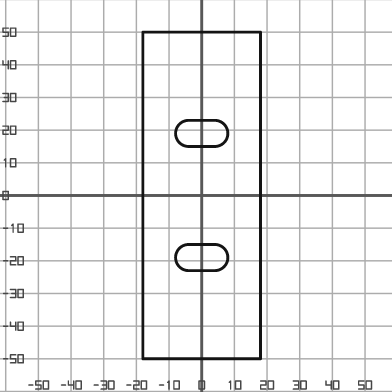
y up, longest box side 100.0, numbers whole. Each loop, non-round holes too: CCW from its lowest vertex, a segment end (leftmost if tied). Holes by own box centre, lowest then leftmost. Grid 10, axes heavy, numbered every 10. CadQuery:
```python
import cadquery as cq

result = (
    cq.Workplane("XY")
    .moveTo(-18.0, -50.0)
    .lineTo(18.0, -50.0)
    .lineTo(18.0, 50.0)
    .lineTo(-18.0, 50.0)
    .close()
    .moveTo(-4.0, -23.0)
    .lineTo(4.0, -23.0)
    .threePointArc((8.0, -19.0), (4.0, -15.0))
    .lineTo(-4.0, -15.0)
    .threePointArc((-8.0, -19.0), (-4.0, -23.0))
    .close()
    .moveTo(-4.0, 15.0)
    .lineTo(4.0, 15.0)
    .threePointArc((8.0, 19.0), (4.0, 23.0))
    .lineTo(-4.0, 23.0)
    .threePointArc((-8.0, 19.0), (-4.0, 15.0))
    .close()
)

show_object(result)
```